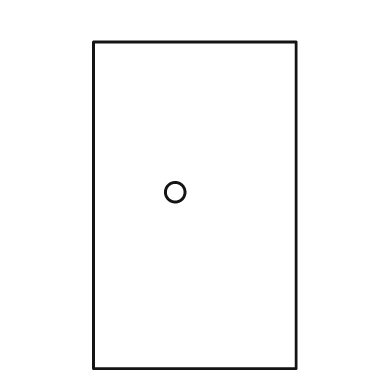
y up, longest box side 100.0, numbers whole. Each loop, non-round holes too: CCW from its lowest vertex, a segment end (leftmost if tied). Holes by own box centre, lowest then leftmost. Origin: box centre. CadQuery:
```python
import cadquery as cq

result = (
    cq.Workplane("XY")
    .moveTo(-31.0, -50.0)
    .lineTo(31.0, -50.0)
    .lineTo(31.0, 50.0)
    .lineTo(-31.0, 50.0)
    .close()
    .moveTo(-6.0, 4.0)
    .circle(3.0)
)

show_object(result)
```